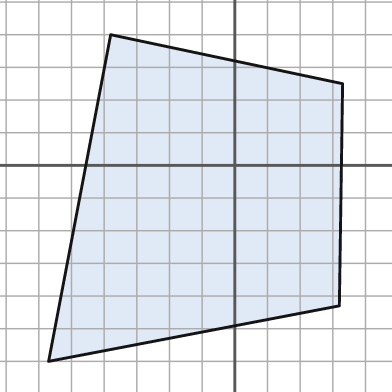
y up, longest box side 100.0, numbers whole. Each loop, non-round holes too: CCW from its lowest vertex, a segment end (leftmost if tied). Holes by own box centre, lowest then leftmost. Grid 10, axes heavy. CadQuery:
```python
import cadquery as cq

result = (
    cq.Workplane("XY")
    .moveTo(-57.0, -60.0)
    .lineTo(32.0, -43.0)
    .lineTo(33.0, 25.0)
    .lineTo(-38.0, 40.0)
    .close()
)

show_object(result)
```